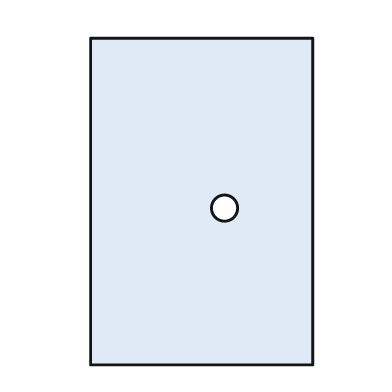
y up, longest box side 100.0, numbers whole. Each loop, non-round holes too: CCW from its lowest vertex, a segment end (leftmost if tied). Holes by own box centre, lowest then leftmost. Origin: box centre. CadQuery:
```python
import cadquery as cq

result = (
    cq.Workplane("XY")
    .moveTo(-34.0, -50.0)
    .lineTo(34.0, -50.0)
    .lineTo(34.0, 50.0)
    .lineTo(-34.0, 50.0)
    .close()
    .moveTo(7.0, -2.0)
    .circle(4.0)
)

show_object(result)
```